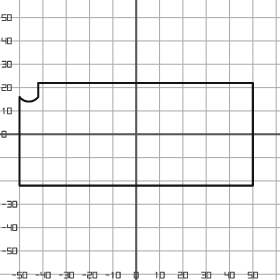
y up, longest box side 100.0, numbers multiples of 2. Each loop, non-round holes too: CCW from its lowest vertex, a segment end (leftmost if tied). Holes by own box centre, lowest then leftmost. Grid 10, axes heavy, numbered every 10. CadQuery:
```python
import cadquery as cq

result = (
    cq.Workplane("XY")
    .moveTo(-50.0, -22.0)
    .lineTo(50.0, -22.0)
    .lineTo(50.0, 22.0)
    .lineTo(-42.0, 22.0)
    .lineTo(-42.0, 16.0)
    .threePointArc((-46.0, 14.0), (-50.0, 16.0))
    .close()
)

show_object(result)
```